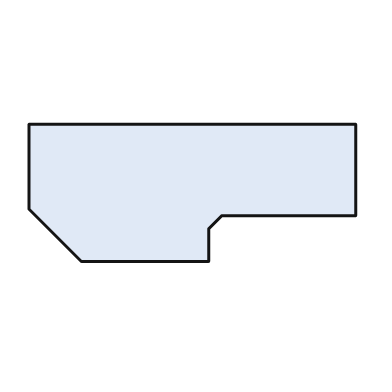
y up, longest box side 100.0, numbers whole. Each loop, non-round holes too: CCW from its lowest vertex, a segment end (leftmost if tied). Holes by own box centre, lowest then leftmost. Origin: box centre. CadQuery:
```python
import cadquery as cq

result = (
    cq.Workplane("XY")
    .moveTo(-34.0, -21.0)
    .lineTo(5.0, -21.0)
    .lineTo(5.0, -11.0)
    .lineTo(9.0, -7.0)
    .lineTo(50.0, -7.0)
    .lineTo(50.0, 21.0)
    .lineTo(-50.0, 21.0)
    .lineTo(-50.0, -5.0)
    .close()
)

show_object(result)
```